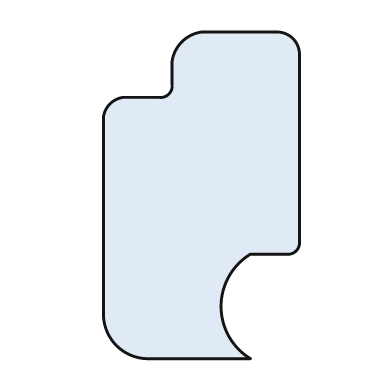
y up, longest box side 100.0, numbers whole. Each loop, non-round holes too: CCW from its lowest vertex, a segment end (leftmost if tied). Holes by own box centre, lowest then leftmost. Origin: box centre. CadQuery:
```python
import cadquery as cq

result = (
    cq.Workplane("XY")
    .moveTo(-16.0, -50.0)
    .lineTo(15.0, -50.0)
    .threePointArc((6.0, -34.0), (15.0, -18.0))
    .lineTo(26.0, -18.0)
    .threePointArc((29.0, -17.0), (30.0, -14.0))
    .lineTo(30.0, 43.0)
    .threePointArc((28.0, 48.0), (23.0, 50.0))
    .lineTo(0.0, 50.0)
    .threePointArc((-6.0, 47.0), (-9.0, 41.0))
    .lineTo(-9.0, 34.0)
    .threePointArc((-10.0, 31.0), (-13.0, 30.0))
    .lineTo(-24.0, 30.0)
    .threePointArc((-28.0, 28.0), (-30.0, 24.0))
    .lineTo(-30.0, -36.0)
    .threePointArc((-26.0, -46.0), (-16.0, -50.0))
    .close()
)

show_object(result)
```